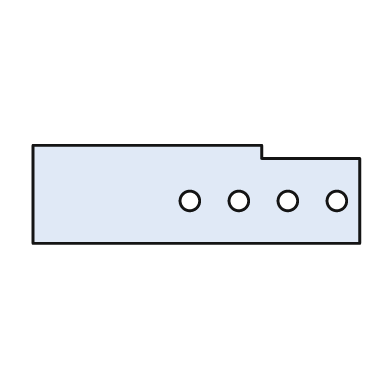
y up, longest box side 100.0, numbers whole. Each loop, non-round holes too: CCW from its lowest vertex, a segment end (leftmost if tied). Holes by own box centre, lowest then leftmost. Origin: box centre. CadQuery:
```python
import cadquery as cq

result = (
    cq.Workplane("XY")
    .moveTo(-50.0, -15.0)
    .lineTo(50.0, -15.0)
    .lineTo(50.0, 11.0)
    .lineTo(20.0, 11.0)
    .lineTo(20.0, 15.0)
    .lineTo(-50.0, 15.0)
    .close()
    .moveTo(-2.0, -2.0)
    .circle(3.0)
    .moveTo(13.0, -2.0)
    .circle(3.0)
    .moveTo(28.0, -2.0)
    .circle(3.0)
    .moveTo(43.0, -2.0)
    .circle(3.0)
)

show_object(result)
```